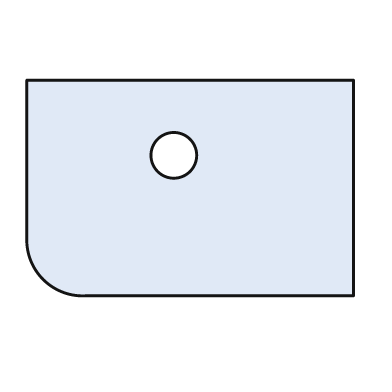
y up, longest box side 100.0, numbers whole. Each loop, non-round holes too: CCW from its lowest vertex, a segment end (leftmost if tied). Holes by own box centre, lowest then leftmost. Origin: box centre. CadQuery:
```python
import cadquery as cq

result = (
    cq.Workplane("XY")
    .moveTo(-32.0, -33.0)
    .lineTo(50.0, -33.0)
    .lineTo(50.0, 33.0)
    .lineTo(-50.0, 33.0)
    .lineTo(-50.0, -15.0)
    .threePointArc((-45.0, -28.0), (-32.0, -33.0))
    .close()
    .moveTo(-5.0, 10.0)
    .circle(7.0)
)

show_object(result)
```